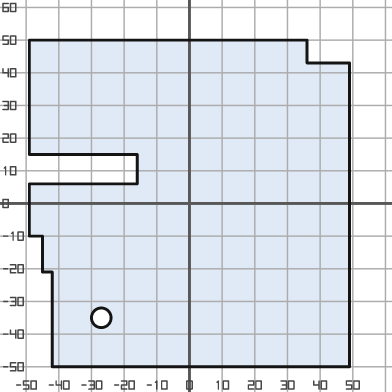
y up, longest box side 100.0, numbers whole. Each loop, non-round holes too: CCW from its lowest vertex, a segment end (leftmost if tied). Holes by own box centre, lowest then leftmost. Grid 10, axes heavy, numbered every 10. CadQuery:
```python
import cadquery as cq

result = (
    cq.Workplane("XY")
    .moveTo(-42.0, -50.0)
    .lineTo(49.0, -50.0)
    .lineTo(49.0, 43.0)
    .lineTo(36.0, 43.0)
    .lineTo(36.0, 50.0)
    .lineTo(-49.0, 50.0)
    .lineTo(-49.0, 15.0)
    .lineTo(-16.0, 15.0)
    .lineTo(-16.0, 6.0)
    .lineTo(-49.0, 6.0)
    .lineTo(-49.0, -10.0)
    .lineTo(-45.0, -10.0)
    .lineTo(-45.0, -21.0)
    .lineTo(-42.0, -21.0)
    .close()
    .moveTo(-27.0, -35.0)
    .circle(3.0)
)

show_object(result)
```